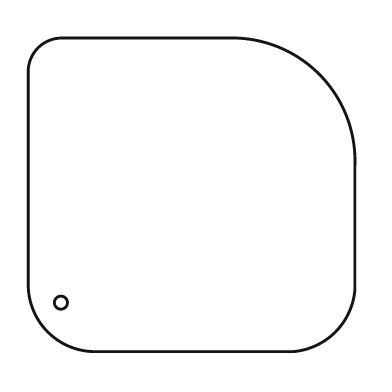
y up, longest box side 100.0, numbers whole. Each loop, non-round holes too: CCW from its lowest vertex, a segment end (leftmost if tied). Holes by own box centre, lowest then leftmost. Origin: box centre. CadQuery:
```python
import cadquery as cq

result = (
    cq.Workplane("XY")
    .moveTo(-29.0, -48.0)
    .lineTo(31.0, -48.0)
    .threePointArc((44.0, -42.0), (50.0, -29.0))
    .lineTo(50.0, 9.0)
    .threePointArc((39.0, 37.0), (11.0, 48.0))
    .lineTo(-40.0, 48.0)
    .threePointArc((-47.0, 45.0), (-50.0, 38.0))
    .lineTo(-50.0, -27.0)
    .threePointArc((-44.0, -42.0), (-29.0, -48.0))
    .close()
    .moveTo(-40.0, -33.0)
    .circle(2.0)
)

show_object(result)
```